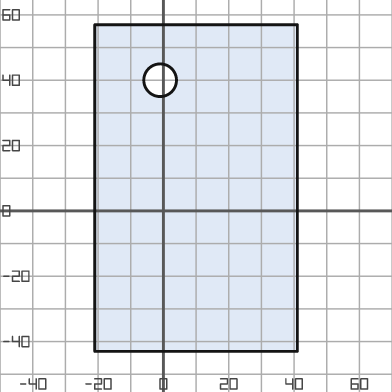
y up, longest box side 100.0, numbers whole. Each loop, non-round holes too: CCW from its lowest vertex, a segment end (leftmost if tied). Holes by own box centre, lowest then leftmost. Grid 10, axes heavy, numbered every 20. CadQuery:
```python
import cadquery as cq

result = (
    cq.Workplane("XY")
    .moveTo(-21.0, -43.0)
    .lineTo(41.0, -43.0)
    .lineTo(41.0, 57.0)
    .lineTo(-21.0, 57.0)
    .close()
    .moveTo(-1.0, 40.0)
    .circle(5.0)
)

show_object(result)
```